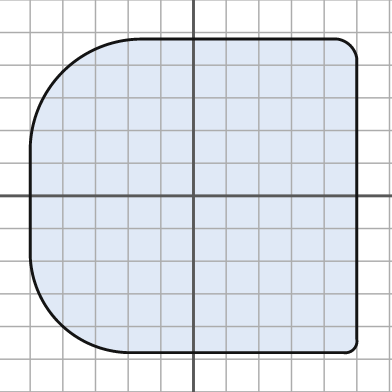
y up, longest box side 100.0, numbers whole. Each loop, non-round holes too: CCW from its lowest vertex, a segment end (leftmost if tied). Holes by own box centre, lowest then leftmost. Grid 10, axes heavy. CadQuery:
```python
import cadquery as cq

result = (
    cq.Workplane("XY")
    .moveTo(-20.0, -48.0)
    .lineTo(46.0, -48.0)
    .threePointArc((49.0, -47.0), (50.0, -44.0))
    .lineTo(50.0, 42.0)
    .threePointArc((48.0, 46.0), (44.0, 48.0))
    .lineTo(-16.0, 48.0)
    .threePointArc((-40.0, 38.0), (-50.0, 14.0))
    .lineTo(-50.0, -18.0)
    .threePointArc((-41.0, -39.0), (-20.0, -48.0))
    .close()
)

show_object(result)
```